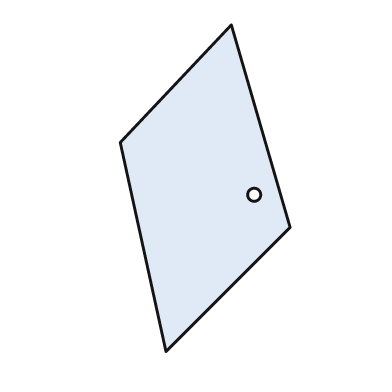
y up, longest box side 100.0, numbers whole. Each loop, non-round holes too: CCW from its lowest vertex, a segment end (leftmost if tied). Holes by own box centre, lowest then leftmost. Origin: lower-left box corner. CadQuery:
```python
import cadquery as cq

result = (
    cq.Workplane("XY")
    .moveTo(14.0, 0.0)
    .lineTo(52.0, 38.0)
    .lineTo(34.0, 100.0)
    .lineTo(0.0, 64.0)
    .close()
    .moveTo(41.0, 48.0)
    .circle(2.0)
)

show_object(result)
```